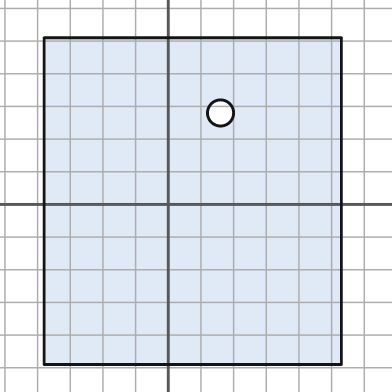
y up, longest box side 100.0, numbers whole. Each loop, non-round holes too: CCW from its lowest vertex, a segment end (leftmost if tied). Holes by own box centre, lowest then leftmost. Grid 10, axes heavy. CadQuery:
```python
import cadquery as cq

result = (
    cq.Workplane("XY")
    .moveTo(-38.0, -49.0)
    .lineTo(53.0, -49.0)
    .lineTo(53.0, 51.0)
    .lineTo(-38.0, 51.0)
    .close()
    .moveTo(16.0, 28.0)
    .circle(4.0)
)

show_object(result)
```